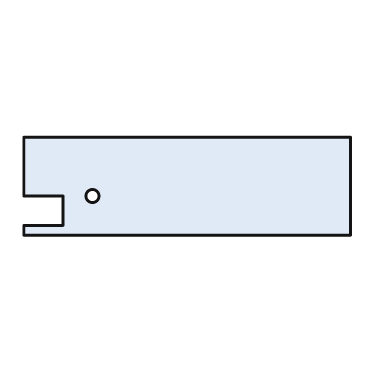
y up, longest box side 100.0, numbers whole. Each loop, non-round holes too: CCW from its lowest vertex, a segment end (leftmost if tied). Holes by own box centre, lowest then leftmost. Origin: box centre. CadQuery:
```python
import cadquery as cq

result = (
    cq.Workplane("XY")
    .moveTo(-50.0, -15.0)
    .lineTo(50.0, -15.0)
    .lineTo(50.0, 15.0)
    .lineTo(-50.0, 15.0)
    .lineTo(-50.0, -3.0)
    .lineTo(-38.0, -3.0)
    .lineTo(-38.0, -12.0)
    .lineTo(-50.0, -12.0)
    .close()
    .moveTo(-29.0, -3.0)
    .circle(2.0)
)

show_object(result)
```